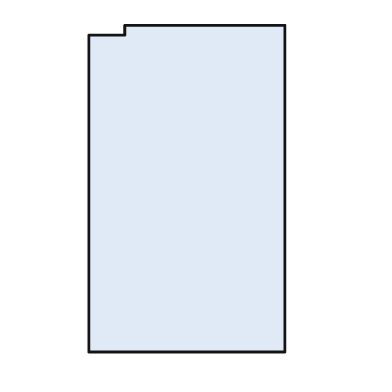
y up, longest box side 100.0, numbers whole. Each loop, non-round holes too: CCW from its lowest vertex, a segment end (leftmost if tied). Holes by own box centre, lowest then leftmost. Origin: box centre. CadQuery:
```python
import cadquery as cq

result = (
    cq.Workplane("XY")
    .moveTo(-30.0, -50.0)
    .lineTo(30.0, -50.0)
    .lineTo(30.0, 50.0)
    .lineTo(-19.0, 50.0)
    .lineTo(-19.0, 47.0)
    .lineTo(-30.0, 47.0)
    .close()
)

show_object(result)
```